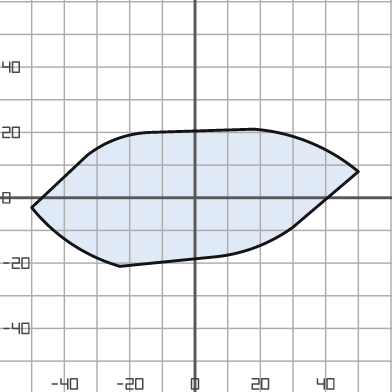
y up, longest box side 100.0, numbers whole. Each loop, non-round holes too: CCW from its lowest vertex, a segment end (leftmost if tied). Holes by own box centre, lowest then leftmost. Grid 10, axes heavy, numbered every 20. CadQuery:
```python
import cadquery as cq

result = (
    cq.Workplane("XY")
    .moveTo(-23.0, -21.0)
    .lineTo(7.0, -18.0)
    .threePointArc((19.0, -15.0), (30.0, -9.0))
    .lineTo(50.0, 8.0)
    .threePointArc((35.0, 17.0), (18.0, 21.0))
    .lineTo(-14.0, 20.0)
    .threePointArc((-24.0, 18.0), (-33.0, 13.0))
    .lineTo(-50.0, -3.0)
    .threePointArc((-38.0, -14.0), (-23.0, -21.0))
    .close()
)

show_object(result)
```